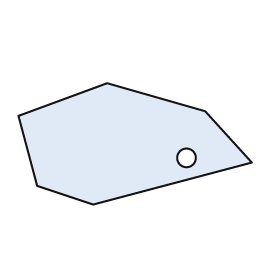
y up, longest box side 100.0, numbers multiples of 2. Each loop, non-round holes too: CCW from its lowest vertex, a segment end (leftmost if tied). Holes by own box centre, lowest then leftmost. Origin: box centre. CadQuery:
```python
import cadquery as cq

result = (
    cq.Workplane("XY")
    .moveTo(-18.0, -26.0)
    .lineTo(50.0, -8.0)
    .lineTo(30.0, 14.0)
    .lineTo(-12.0, 26.0)
    .lineTo(-50.0, 12.0)
    .lineTo(-42.0, -18.0)
    .close()
    .moveTo(22.0, -6.0)
    .circle(4.0)
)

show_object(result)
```